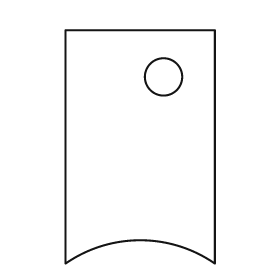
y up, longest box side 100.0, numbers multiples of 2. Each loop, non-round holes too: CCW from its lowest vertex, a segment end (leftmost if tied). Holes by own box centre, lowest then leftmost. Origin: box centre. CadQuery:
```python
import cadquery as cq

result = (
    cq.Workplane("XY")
    .moveTo(-32.0, -50.0)
    .threePointArc((0.0, -40.0), (32.0, -50.0))
    .lineTo(32.0, 50.0)
    .lineTo(-32.0, 50.0)
    .close()
    .moveTo(10.0, 30.0)
    .circle(8.0)
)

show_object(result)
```